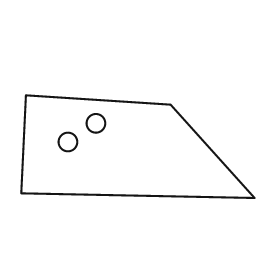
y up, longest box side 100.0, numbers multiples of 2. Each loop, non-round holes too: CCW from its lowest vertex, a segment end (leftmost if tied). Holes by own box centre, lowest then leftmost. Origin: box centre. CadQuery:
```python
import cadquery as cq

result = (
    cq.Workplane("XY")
    .moveTo(50.0, -22.0)
    .lineTo(14.0, 18.0)
    .lineTo(-48.0, 22.0)
    .lineTo(-50.0, -20.0)
    .close()
    .moveTo(-30.0, 2.0)
    .circle(4.0)
    .moveTo(-18.0, 10.0)
    .circle(4.0)
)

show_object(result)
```